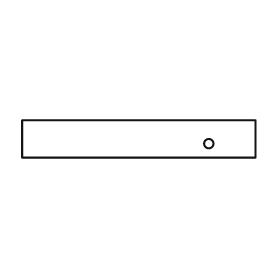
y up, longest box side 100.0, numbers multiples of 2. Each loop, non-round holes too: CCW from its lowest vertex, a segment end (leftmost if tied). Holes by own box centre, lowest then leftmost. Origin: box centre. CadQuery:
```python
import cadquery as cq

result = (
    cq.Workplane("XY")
    .moveTo(-50.0, -8.0)
    .lineTo(50.0, -8.0)
    .lineTo(50.0, 8.0)
    .lineTo(-50.0, 8.0)
    .close()
    .moveTo(30.0, -2.0)
    .circle(2.0)
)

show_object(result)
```